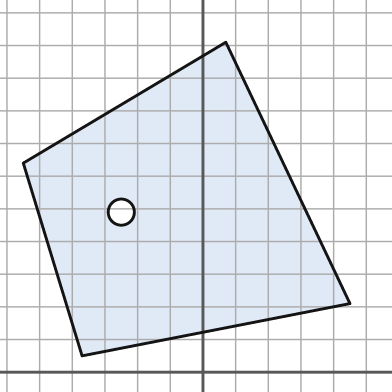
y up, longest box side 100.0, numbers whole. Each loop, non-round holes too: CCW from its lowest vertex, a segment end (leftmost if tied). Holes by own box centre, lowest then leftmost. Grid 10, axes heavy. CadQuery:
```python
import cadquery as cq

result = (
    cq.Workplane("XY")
    .moveTo(-37.0, 5.0)
    .lineTo(45.0, 21.0)
    .lineTo(7.0, 101.0)
    .lineTo(-55.0, 64.0)
    .close()
    .moveTo(-25.0, 49.0)
    .circle(4.0)
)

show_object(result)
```